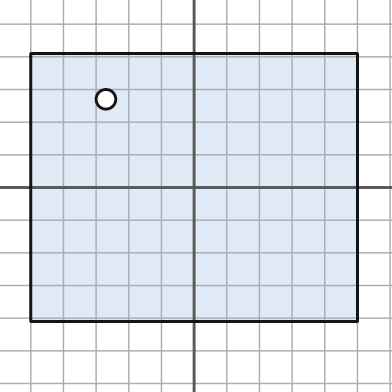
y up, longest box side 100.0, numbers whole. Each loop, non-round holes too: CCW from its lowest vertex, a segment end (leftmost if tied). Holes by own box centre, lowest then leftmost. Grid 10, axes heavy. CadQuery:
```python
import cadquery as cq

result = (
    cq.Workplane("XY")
    .moveTo(-50.0, -41.0)
    .lineTo(50.0, -41.0)
    .lineTo(50.0, 41.0)
    .lineTo(-50.0, 41.0)
    .close()
    .moveTo(-27.0, 27.0)
    .circle(3.0)
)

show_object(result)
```